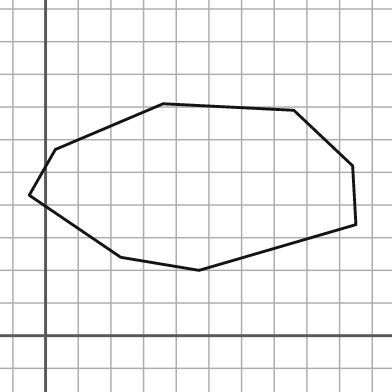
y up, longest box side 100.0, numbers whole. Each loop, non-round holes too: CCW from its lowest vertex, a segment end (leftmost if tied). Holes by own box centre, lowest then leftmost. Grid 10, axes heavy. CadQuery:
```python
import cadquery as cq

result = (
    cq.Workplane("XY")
    .moveTo(47.0, 20.0)
    .lineTo(95.0, 34.0)
    .lineTo(94.0, 52.0)
    .lineTo(76.0, 69.0)
    .lineTo(36.0, 71.0)
    .lineTo(3.0, 57.0)
    .lineTo(-5.0, 43.0)
    .lineTo(23.0, 24.0)
    .close()
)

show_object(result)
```